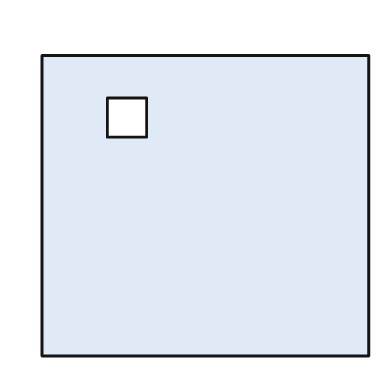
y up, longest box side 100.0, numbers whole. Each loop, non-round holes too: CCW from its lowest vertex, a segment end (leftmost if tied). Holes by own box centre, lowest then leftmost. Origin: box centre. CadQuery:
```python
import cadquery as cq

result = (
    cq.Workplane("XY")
    .moveTo(-50.0, -46.0)
    .lineTo(50.0, -46.0)
    .lineTo(50.0, 46.0)
    .lineTo(-50.0, 46.0)
    .close()
    .moveTo(-30.0, 21.0)
    .lineTo(-18.0, 21.0)
    .lineTo(-18.0, 33.0)
    .lineTo(-30.0, 33.0)
    .close()
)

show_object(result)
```